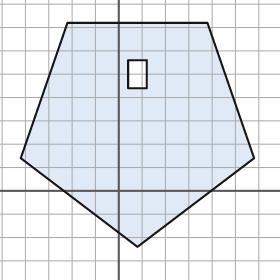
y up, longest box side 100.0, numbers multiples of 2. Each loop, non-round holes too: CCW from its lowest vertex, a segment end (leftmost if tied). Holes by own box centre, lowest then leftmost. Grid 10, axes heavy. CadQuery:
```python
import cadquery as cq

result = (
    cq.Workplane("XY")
    .moveTo(8.0, -24.0)
    .lineTo(58.0, 14.0)
    .lineTo(38.0, 72.0)
    .lineTo(-22.0, 72.0)
    .lineTo(-42.0, 14.0)
    .close()
    .moveTo(4.0, 44.0)
    .lineTo(12.0, 44.0)
    .lineTo(12.0, 56.0)
    .lineTo(4.0, 56.0)
    .close()
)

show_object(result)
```